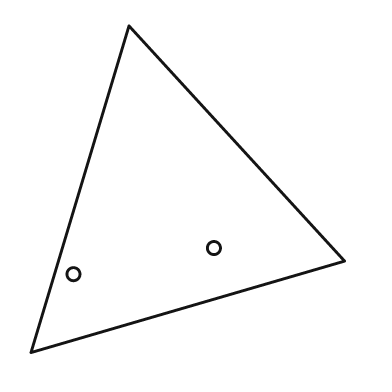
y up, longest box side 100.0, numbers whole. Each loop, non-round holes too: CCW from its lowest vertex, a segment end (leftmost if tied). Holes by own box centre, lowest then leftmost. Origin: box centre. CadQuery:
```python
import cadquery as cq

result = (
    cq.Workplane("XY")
    .moveTo(-48.0, -50.0)
    .lineTo(48.0, -22.0)
    .lineTo(-18.0, 50.0)
    .close()
    .moveTo(-35.0, -26.0)
    .circle(2.0)
    .moveTo(8.0, -18.0)
    .circle(2.0)
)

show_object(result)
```